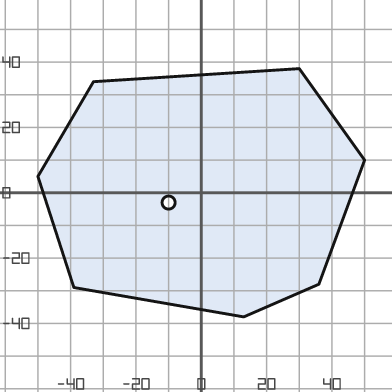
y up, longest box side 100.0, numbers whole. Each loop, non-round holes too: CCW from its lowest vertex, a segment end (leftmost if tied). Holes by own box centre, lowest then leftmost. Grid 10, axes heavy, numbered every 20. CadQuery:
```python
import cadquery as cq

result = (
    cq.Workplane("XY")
    .moveTo(13.0, -38.0)
    .lineTo(36.0, -28.0)
    .lineTo(50.0, 10.0)
    .lineTo(30.0, 38.0)
    .lineTo(-33.0, 34.0)
    .lineTo(-50.0, 5.0)
    .lineTo(-39.0, -29.0)
    .close()
    .moveTo(-10.0, -3.0)
    .circle(2.0)
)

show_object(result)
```